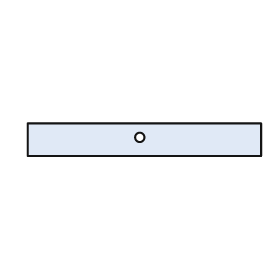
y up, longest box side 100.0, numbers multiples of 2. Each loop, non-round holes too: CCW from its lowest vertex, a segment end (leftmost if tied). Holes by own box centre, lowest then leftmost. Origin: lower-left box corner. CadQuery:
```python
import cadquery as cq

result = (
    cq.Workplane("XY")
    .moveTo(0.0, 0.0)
    .lineTo(100.0, 0.0)
    .lineTo(100.0, 14.0)
    .lineTo(0.0, 14.0)
    .close()
    .moveTo(48.0, 8.0)
    .circle(2.0)
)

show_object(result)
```